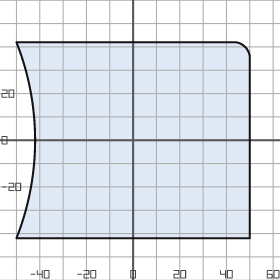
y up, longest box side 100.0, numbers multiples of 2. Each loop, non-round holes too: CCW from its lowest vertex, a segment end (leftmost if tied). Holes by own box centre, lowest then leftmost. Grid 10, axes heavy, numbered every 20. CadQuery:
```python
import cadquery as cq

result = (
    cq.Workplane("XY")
    .moveTo(-50.0, -42.0)
    .lineTo(50.0, -42.0)
    .lineTo(50.0, 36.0)
    .threePointArc((48.0, 40.0), (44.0, 42.0))
    .lineTo(-50.0, 42.0)
    .threePointArc((-42.0, 0.0), (-50.0, -42.0))
    .close()
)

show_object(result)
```